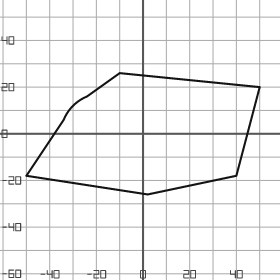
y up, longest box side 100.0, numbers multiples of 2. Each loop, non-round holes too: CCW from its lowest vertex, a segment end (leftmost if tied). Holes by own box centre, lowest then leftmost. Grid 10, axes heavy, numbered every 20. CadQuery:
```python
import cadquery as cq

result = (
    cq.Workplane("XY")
    .moveTo(2.0, -26.0)
    .lineTo(40.0, -18.0)
    .lineTo(50.0, 20.0)
    .lineTo(-10.0, 26.0)
    .lineTo(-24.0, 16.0)
    .threePointArc((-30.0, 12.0), (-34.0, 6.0))
    .lineTo(-50.0, -18.0)
    .close()
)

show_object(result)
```